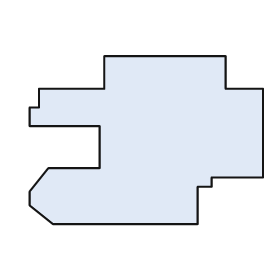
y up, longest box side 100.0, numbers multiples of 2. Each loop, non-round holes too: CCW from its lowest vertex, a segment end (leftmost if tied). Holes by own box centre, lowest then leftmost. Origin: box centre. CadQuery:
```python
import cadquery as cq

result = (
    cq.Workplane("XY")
    .moveTo(-40.0, -36.0)
    .lineTo(22.0, -36.0)
    .lineTo(22.0, -20.0)
    .lineTo(28.0, -20.0)
    .lineTo(28.0, -16.0)
    .lineTo(50.0, -16.0)
    .lineTo(50.0, 22.0)
    .lineTo(34.0, 22.0)
    .lineTo(34.0, 36.0)
    .lineTo(-18.0, 36.0)
    .lineTo(-18.0, 22.0)
    .lineTo(-46.0, 22.0)
    .lineTo(-46.0, 14.0)
    .lineTo(-50.0, 14.0)
    .lineTo(-50.0, 6.0)
    .lineTo(-20.0, 6.0)
    .lineTo(-20.0, -12.0)
    .lineTo(-42.0, -12.0)
    .lineTo(-50.0, -22.0)
    .lineTo(-50.0, -28.0)
    .close()
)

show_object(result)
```